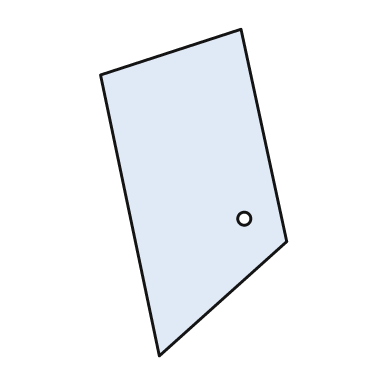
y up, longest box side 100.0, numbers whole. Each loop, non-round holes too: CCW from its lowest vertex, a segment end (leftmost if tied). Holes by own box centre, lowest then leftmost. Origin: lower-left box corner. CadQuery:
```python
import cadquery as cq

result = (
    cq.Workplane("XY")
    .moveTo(18.0, 0.0)
    .lineTo(57.0, 35.0)
    .lineTo(43.0, 100.0)
    .lineTo(0.0, 86.0)
    .close()
    .moveTo(44.0, 42.0)
    .circle(2.0)
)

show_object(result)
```